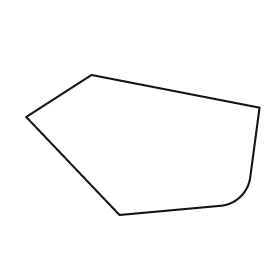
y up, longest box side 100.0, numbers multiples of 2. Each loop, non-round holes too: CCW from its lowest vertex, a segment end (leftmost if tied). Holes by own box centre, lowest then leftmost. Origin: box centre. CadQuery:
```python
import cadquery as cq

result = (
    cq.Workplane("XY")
    .moveTo(-10.0, -30.0)
    .lineTo(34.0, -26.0)
    .threePointArc((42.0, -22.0), (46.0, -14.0))
    .lineTo(50.0, 16.0)
    .lineTo(-22.0, 30.0)
    .lineTo(-50.0, 12.0)
    .close()
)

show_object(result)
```